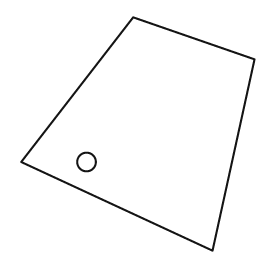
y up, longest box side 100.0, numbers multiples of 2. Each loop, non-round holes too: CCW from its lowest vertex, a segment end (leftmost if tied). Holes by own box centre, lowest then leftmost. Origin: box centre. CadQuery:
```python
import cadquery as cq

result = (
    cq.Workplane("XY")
    .moveTo(32.0, -50.0)
    .lineTo(50.0, 32.0)
    .lineTo(-2.0, 50.0)
    .lineTo(-50.0, -12.0)
    .close()
    .moveTo(-22.0, -12.0)
    .circle(4.0)
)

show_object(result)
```